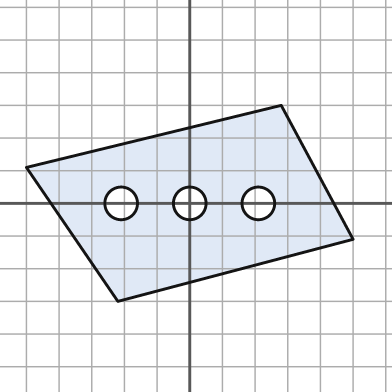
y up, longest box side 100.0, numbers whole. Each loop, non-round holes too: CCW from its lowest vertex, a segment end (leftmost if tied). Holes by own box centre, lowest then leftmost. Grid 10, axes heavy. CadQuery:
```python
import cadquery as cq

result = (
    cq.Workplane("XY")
    .moveTo(-22.0, -30.0)
    .lineTo(50.0, -11.0)
    .lineTo(28.0, 30.0)
    .lineTo(-50.0, 11.0)
    .close()
    .moveTo(-21.0, 0.0)
    .circle(5.0)
    .moveTo(0.0, 0.0)
    .circle(5.0)
    .moveTo(21.0, 0.0)
    .circle(5.0)
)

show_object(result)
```